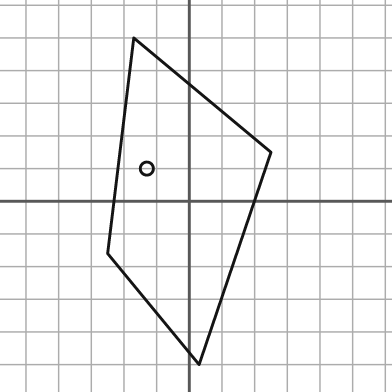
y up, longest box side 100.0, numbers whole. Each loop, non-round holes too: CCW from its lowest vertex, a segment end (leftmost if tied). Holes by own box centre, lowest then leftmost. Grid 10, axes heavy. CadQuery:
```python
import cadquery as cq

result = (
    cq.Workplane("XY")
    .moveTo(3.0, -50.0)
    .lineTo(25.0, 15.0)
    .lineTo(-17.0, 50.0)
    .lineTo(-25.0, -16.0)
    .close()
    .moveTo(-13.0, 10.0)
    .circle(2.0)
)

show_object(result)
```